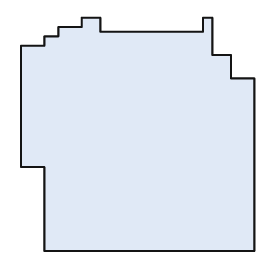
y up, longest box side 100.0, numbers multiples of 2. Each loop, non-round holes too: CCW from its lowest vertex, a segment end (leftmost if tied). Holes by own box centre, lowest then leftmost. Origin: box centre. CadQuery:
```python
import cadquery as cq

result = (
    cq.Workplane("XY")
    .moveTo(-40.0, -50.0)
    .lineTo(50.0, -50.0)
    .lineTo(50.0, 24.0)
    .lineTo(40.0, 24.0)
    .lineTo(40.0, 34.0)
    .lineTo(32.0, 34.0)
    .lineTo(32.0, 50.0)
    .lineTo(28.0, 50.0)
    .lineTo(28.0, 44.0)
    .lineTo(-16.0, 44.0)
    .lineTo(-16.0, 50.0)
    .lineTo(-24.0, 50.0)
    .lineTo(-24.0, 46.0)
    .lineTo(-34.0, 46.0)
    .lineTo(-34.0, 42.0)
    .lineTo(-40.0, 42.0)
    .lineTo(-40.0, 38.0)
    .lineTo(-50.0, 38.0)
    .lineTo(-50.0, -14.0)
    .lineTo(-40.0, -14.0)
    .close()
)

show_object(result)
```